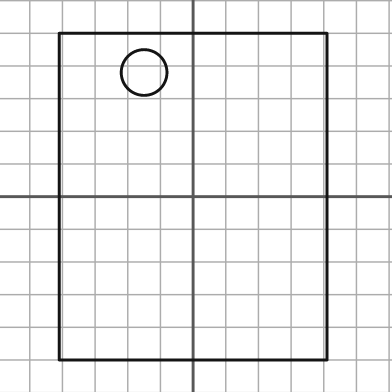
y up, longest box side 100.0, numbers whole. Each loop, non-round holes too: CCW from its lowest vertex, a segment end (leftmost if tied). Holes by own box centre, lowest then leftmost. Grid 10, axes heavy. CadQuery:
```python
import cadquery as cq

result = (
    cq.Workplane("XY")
    .moveTo(-41.0, -50.0)
    .lineTo(41.0, -50.0)
    .lineTo(41.0, 50.0)
    .lineTo(-41.0, 50.0)
    .close()
    .moveTo(-15.0, 38.0)
    .circle(7.0)
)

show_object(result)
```